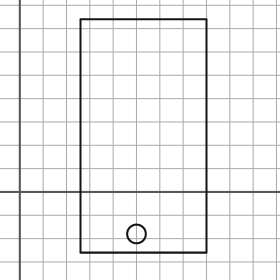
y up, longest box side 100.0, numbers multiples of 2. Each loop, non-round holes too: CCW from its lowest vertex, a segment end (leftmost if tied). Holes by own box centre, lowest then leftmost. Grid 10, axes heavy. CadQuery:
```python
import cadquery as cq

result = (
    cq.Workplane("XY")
    .moveTo(26.0, -26.0)
    .lineTo(80.0, -26.0)
    .lineTo(80.0, 74.0)
    .lineTo(26.0, 74.0)
    .close()
    .moveTo(50.0, -18.0)
    .circle(4.0)
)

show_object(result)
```